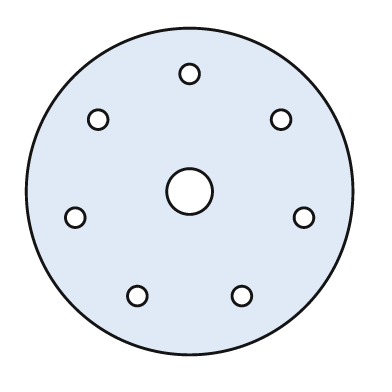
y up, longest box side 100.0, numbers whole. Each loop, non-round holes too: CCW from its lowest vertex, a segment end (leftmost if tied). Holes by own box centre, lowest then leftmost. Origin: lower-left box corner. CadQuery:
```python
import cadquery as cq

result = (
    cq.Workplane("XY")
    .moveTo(50.0, 50.0)
    .circle(50.0)
    .moveTo(34.0, 18.0)
    .circle(3.0)
    .moveTo(66.0, 18.0)
    .circle(3.0)
    .moveTo(15.0, 42.0)
    .circle(3.0)
    .moveTo(85.0, 42.0)
    .circle(3.0)
    .moveTo(50.0, 50.0)
    .circle(7.0)
    .moveTo(22.0, 72.0)
    .circle(3.0)
    .moveTo(78.0, 72.0)
    .circle(3.0)
    .moveTo(50.0, 86.0)
    .circle(3.0)
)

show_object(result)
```